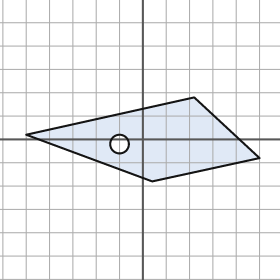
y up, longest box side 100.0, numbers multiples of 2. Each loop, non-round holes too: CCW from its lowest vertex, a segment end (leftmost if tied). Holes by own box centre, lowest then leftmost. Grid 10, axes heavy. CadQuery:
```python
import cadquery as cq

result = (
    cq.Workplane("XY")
    .moveTo(4.0, -18.0)
    .lineTo(50.0, -8.0)
    .lineTo(22.0, 18.0)
    .lineTo(-50.0, 2.0)
    .close()
    .moveTo(-10.0, -2.0)
    .circle(4.0)
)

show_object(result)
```